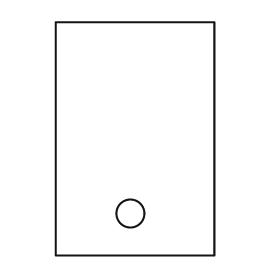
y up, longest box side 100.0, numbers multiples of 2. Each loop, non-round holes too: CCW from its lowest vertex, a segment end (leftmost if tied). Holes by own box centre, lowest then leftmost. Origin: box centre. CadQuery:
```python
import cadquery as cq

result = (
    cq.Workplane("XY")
    .moveTo(-34.0, -50.0)
    .lineTo(34.0, -50.0)
    .lineTo(34.0, 50.0)
    .lineTo(-34.0, 50.0)
    .close()
    .moveTo(-2.0, -32.0)
    .circle(6.0)
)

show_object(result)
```